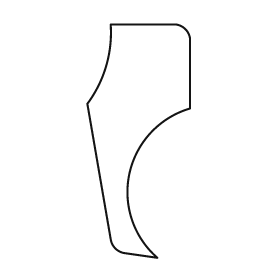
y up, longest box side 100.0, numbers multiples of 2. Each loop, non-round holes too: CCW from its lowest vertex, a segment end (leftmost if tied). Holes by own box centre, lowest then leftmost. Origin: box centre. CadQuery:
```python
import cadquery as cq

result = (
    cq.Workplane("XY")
    .moveTo(8.0, -50.0)
    .threePointArc((-4.0, -14.0), (22.0, 14.0))
    .lineTo(22.0, 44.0)
    .threePointArc((20.0, 48.0), (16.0, 50.0))
    .lineTo(-12.0, 50.0)
    .threePointArc((-14.0, 32.0), (-22.0, 16.0))
    .lineTo(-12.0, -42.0)
    .threePointArc((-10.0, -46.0), (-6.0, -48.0))
    .close()
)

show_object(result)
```